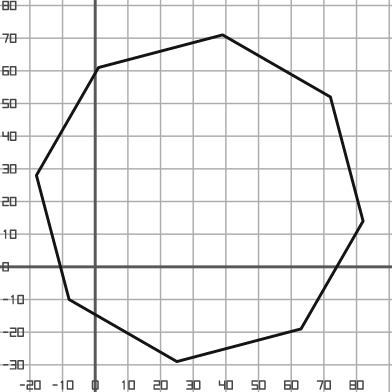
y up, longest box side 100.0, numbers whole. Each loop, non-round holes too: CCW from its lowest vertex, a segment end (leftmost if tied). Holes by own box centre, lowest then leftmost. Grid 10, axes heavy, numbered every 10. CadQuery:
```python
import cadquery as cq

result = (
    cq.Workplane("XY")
    .moveTo(25.0, -29.0)
    .lineTo(63.0, -19.0)
    .lineTo(82.0, 14.0)
    .lineTo(72.0, 52.0)
    .lineTo(39.0, 71.0)
    .lineTo(1.0, 61.0)
    .lineTo(-18.0, 28.0)
    .lineTo(-8.0, -10.0)
    .close()
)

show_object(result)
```